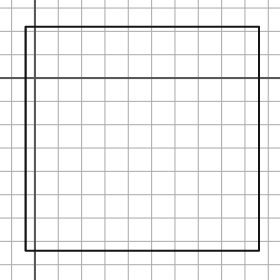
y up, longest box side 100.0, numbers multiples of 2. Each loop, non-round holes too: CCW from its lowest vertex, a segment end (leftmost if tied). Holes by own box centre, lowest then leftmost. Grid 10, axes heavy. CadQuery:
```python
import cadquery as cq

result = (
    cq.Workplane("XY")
    .moveTo(-4.0, -74.0)
    .lineTo(96.0, -74.0)
    .lineTo(96.0, 22.0)
    .lineTo(-4.0, 22.0)
    .close()
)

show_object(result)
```